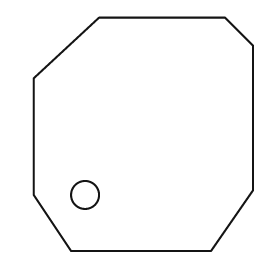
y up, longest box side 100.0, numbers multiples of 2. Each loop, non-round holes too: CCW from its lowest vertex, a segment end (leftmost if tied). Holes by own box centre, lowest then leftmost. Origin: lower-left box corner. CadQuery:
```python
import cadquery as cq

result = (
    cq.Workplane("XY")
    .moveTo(16.0, 0.0)
    .lineTo(76.0, 0.0)
    .lineTo(94.0, 26.0)
    .lineTo(94.0, 88.0)
    .lineTo(82.0, 100.0)
    .lineTo(28.0, 100.0)
    .lineTo(0.0, 74.0)
    .lineTo(0.0, 24.0)
    .close()
    .moveTo(22.0, 24.0)
    .circle(6.0)
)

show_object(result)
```